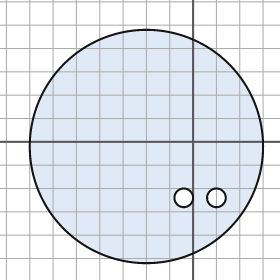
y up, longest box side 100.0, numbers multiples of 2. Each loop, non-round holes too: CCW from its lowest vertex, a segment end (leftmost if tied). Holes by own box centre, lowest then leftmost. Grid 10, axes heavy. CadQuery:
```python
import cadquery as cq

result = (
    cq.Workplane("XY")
    .moveTo(-20.0, -2.0)
    .circle(50.0)
    .moveTo(-4.0, -24.0)
    .circle(4.0)
    .moveTo(10.0, -24.0)
    .circle(4.0)
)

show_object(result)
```